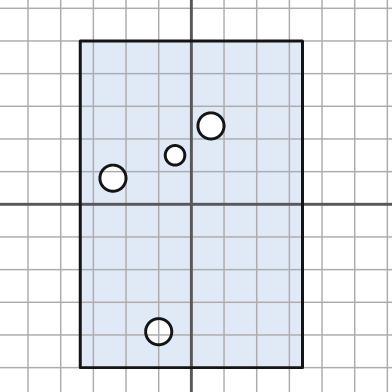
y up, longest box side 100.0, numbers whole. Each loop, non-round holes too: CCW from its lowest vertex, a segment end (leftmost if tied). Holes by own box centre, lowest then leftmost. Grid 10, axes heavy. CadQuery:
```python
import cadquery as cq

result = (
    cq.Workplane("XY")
    .moveTo(-34.0, -50.0)
    .lineTo(34.0, -50.0)
    .lineTo(34.0, 50.0)
    .lineTo(-34.0, 50.0)
    .close()
    .moveTo(-10.0, -39.0)
    .circle(4.0)
    .moveTo(-24.0, 8.0)
    .circle(4.0)
    .moveTo(-5.0, 15.0)
    .circle(3.0)
    .moveTo(6.0, 24.0)
    .circle(4.0)
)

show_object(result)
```